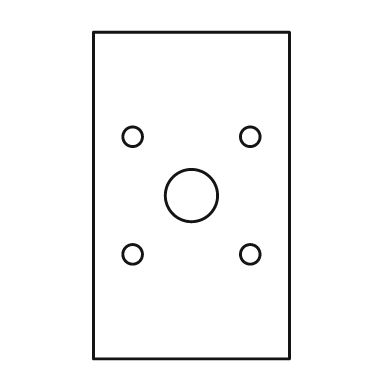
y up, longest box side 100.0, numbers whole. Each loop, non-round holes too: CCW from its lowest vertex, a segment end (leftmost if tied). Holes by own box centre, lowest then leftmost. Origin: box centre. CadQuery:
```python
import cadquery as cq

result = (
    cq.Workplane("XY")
    .moveTo(-30.0, -50.0)
    .lineTo(30.0, -50.0)
    .lineTo(30.0, 50.0)
    .lineTo(-30.0, 50.0)
    .close()
    .moveTo(-18.0, -18.0)
    .circle(3.0)
    .moveTo(18.0, -18.0)
    .circle(3.0)
    .moveTo(0.0, 0.0)
    .circle(8.0)
    .moveTo(-18.0, 18.0)
    .circle(3.0)
    .moveTo(18.0, 18.0)
    .circle(3.0)
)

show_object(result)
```